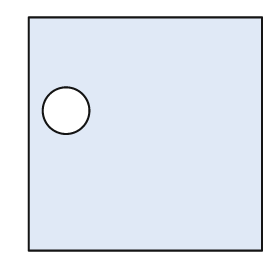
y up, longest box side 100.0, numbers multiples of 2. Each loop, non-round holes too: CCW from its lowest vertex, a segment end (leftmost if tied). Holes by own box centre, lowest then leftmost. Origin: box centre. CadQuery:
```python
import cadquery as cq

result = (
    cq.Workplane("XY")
    .moveTo(-50.0, -50.0)
    .lineTo(50.0, -50.0)
    .lineTo(50.0, 50.0)
    .lineTo(-50.0, 50.0)
    .close()
    .moveTo(-34.0, 10.0)
    .circle(10.0)
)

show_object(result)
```